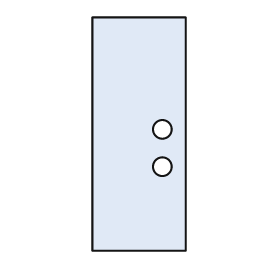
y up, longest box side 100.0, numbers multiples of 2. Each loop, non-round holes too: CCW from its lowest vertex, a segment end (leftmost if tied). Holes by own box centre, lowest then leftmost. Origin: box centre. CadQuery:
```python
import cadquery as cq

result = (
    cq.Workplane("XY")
    .moveTo(-20.0, -50.0)
    .lineTo(20.0, -50.0)
    .lineTo(20.0, 50.0)
    .lineTo(-20.0, 50.0)
    .close()
    .moveTo(10.0, -14.0)
    .circle(4.0)
    .moveTo(10.0, 2.0)
    .circle(4.0)
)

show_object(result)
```